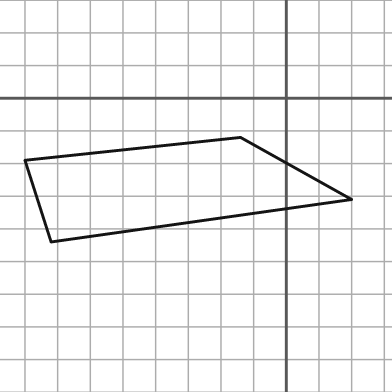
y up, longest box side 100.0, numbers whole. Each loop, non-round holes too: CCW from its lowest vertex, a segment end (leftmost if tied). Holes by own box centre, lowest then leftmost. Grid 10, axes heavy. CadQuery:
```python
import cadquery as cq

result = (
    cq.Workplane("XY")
    .moveTo(-72.0, -44.0)
    .lineTo(20.0, -31.0)
    .lineTo(-14.0, -12.0)
    .lineTo(-80.0, -19.0)
    .close()
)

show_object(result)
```